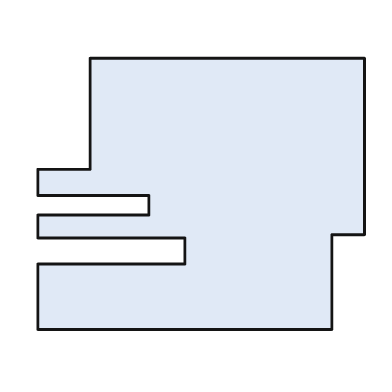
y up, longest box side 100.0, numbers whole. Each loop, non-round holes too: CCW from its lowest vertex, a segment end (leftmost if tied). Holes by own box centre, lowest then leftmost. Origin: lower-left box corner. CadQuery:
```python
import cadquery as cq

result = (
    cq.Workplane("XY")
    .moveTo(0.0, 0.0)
    .lineTo(90.0, 0.0)
    .lineTo(90.0, 29.0)
    .lineTo(100.0, 29.0)
    .lineTo(100.0, 83.0)
    .lineTo(16.0, 83.0)
    .lineTo(16.0, 49.0)
    .lineTo(0.0, 49.0)
    .lineTo(0.0, 41.0)
    .lineTo(34.0, 41.0)
    .lineTo(34.0, 35.0)
    .lineTo(0.0, 35.0)
    .lineTo(0.0, 28.0)
    .lineTo(45.0, 28.0)
    .lineTo(45.0, 20.0)
    .lineTo(0.0, 20.0)
    .close()
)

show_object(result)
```